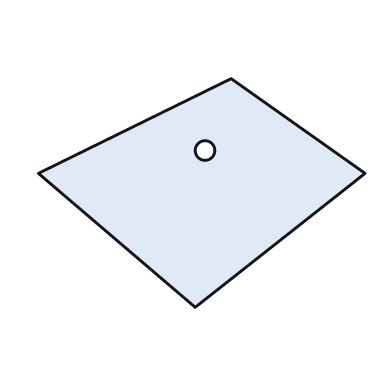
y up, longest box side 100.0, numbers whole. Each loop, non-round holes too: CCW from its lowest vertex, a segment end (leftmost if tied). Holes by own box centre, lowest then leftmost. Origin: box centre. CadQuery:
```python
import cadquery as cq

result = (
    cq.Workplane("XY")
    .moveTo(-2.0, -35.0)
    .lineTo(50.0, 6.0)
    .lineTo(9.0, 35.0)
    .lineTo(-50.0, 6.0)
    .close()
    .moveTo(1.0, 13.0)
    .circle(3.0)
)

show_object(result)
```